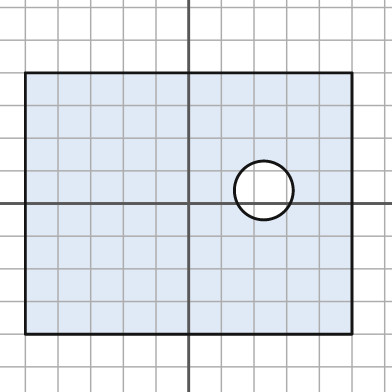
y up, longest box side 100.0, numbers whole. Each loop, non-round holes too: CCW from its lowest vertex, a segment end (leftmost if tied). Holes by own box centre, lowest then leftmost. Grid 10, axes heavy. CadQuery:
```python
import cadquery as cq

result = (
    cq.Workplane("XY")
    .moveTo(-50.0, -40.0)
    .lineTo(50.0, -40.0)
    .lineTo(50.0, 40.0)
    .lineTo(-50.0, 40.0)
    .close()
    .moveTo(23.0, 4.0)
    .circle(9.0)
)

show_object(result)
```